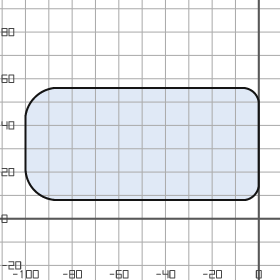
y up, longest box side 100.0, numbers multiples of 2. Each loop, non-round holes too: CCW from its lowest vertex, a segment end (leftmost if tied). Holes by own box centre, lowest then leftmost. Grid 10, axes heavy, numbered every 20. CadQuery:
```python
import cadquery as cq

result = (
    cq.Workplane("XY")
    .moveTo(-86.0, 8.0)
    .lineTo(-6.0, 8.0)
    .threePointArc((-2.0, 10.0), (0.0, 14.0))
    .lineTo(0.0, 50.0)
    .threePointArc((-2.0, 54.0), (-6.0, 56.0))
    .lineTo(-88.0, 56.0)
    .threePointArc((-96.0, 52.0), (-100.0, 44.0))
    .lineTo(-100.0, 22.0)
    .threePointArc((-96.0, 12.0), (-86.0, 8.0))
    .close()
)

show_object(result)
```